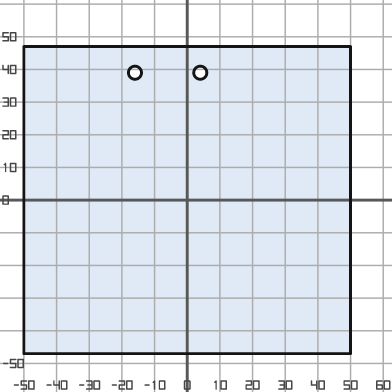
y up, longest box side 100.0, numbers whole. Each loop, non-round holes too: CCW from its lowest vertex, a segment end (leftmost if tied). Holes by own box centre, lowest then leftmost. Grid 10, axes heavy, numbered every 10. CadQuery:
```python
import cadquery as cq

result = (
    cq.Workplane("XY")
    .moveTo(-50.0, -47.0)
    .lineTo(50.0, -47.0)
    .lineTo(50.0, 47.0)
    .lineTo(-50.0, 47.0)
    .close()
    .moveTo(-16.0, 39.0)
    .circle(2.0)
    .moveTo(4.0, 39.0)
    .circle(2.0)
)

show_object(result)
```